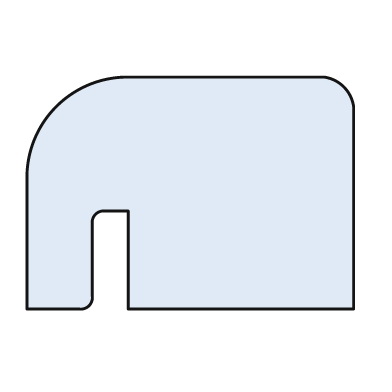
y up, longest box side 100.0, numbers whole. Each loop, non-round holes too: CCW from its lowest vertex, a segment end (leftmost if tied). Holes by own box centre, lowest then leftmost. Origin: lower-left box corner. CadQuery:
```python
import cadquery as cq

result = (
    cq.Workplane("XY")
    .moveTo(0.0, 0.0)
    .lineTo(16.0, 0.0)
    .threePointArc((19.0, 1.0), (20.0, 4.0))
    .lineTo(20.0, 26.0)
    .threePointArc((21.0, 29.0), (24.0, 30.0))
    .lineTo(31.0, 30.0)
    .lineTo(31.0, 0.0)
    .lineTo(100.0, 0.0)
    .lineTo(100.0, 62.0)
    .threePointArc((97.0, 68.0), (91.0, 71.0))
    .lineTo(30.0, 71.0)
    .threePointArc((9.0, 62.0), (0.0, 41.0))
    .close()
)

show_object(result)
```